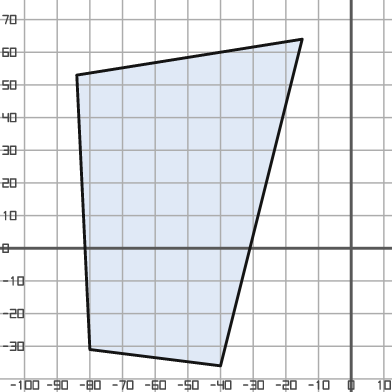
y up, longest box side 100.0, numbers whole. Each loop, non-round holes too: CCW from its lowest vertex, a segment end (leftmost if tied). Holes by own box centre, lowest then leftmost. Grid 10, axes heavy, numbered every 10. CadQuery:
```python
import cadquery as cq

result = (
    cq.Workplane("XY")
    .moveTo(-40.0, -36.0)
    .lineTo(-15.0, 64.0)
    .lineTo(-84.0, 53.0)
    .lineTo(-80.0, -31.0)
    .close()
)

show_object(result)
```